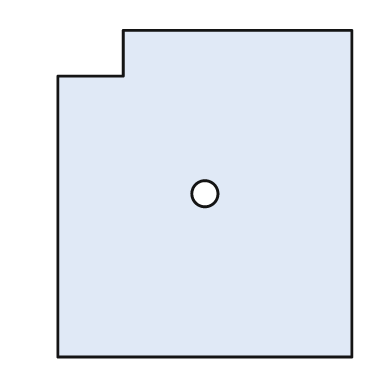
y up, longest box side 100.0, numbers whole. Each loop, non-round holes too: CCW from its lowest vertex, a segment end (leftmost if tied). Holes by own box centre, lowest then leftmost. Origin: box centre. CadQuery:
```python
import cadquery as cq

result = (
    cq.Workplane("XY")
    .moveTo(-45.0, -50.0)
    .lineTo(45.0, -50.0)
    .lineTo(45.0, 50.0)
    .lineTo(-25.0, 50.0)
    .lineTo(-25.0, 36.0)
    .lineTo(-45.0, 36.0)
    .close()
    .moveTo(0.0, 0.0)
    .circle(4.0)
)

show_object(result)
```